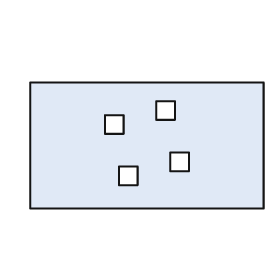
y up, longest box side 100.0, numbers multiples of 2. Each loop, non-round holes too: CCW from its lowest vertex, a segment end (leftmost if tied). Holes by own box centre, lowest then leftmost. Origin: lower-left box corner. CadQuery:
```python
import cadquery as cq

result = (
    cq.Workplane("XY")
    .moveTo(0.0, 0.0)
    .lineTo(100.0, 0.0)
    .lineTo(100.0, 54.0)
    .lineTo(0.0, 54.0)
    .close()
    .moveTo(38.0, 10.0)
    .lineTo(46.0, 10.0)
    .lineTo(46.0, 18.0)
    .lineTo(38.0, 18.0)
    .close()
    .moveTo(60.0, 16.0)
    .lineTo(68.0, 16.0)
    .lineTo(68.0, 24.0)
    .lineTo(60.0, 24.0)
    .close()
    .moveTo(32.0, 32.0)
    .lineTo(40.0, 32.0)
    .lineTo(40.0, 40.0)
    .lineTo(32.0, 40.0)
    .close()
    .moveTo(54.0, 38.0)
    .lineTo(62.0, 38.0)
    .lineTo(62.0, 46.0)
    .lineTo(54.0, 46.0)
    .close()
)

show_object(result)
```